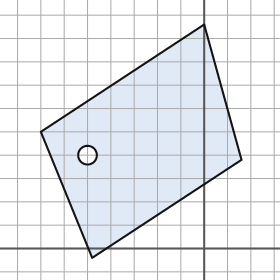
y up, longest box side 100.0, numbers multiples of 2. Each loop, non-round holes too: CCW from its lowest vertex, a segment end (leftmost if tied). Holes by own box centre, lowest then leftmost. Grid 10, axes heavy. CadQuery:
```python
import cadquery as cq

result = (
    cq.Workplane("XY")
    .moveTo(-48.0, -4.0)
    .lineTo(16.0, 38.0)
    .lineTo(0.0, 96.0)
    .lineTo(-70.0, 50.0)
    .close()
    .moveTo(-50.0, 40.0)
    .circle(4.0)
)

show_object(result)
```